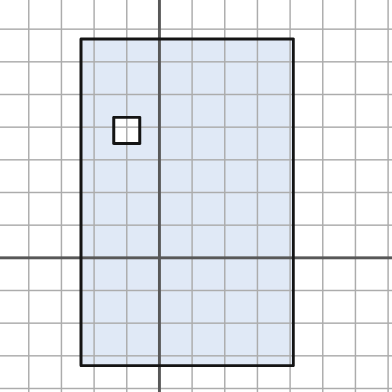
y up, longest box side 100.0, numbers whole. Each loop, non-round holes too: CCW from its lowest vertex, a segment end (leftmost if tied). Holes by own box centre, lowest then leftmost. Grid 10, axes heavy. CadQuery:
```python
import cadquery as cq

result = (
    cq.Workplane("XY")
    .moveTo(-24.0, -33.0)
    .lineTo(41.0, -33.0)
    .lineTo(41.0, 67.0)
    .lineTo(-24.0, 67.0)
    .close()
    .moveTo(-14.0, 35.0)
    .lineTo(-6.0, 35.0)
    .lineTo(-6.0, 43.0)
    .lineTo(-14.0, 43.0)
    .close()
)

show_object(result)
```